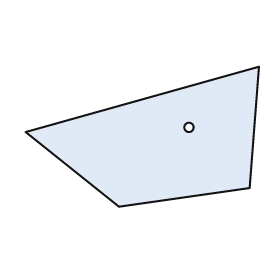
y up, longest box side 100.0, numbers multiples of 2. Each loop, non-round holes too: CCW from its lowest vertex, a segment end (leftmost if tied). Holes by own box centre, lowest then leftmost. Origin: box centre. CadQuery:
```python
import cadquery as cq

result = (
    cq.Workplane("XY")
    .moveTo(-10.0, -30.0)
    .lineTo(46.0, -22.0)
    .lineTo(50.0, 30.0)
    .lineTo(-50.0, 2.0)
    .close()
    .moveTo(20.0, 4.0)
    .circle(2.0)
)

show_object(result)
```